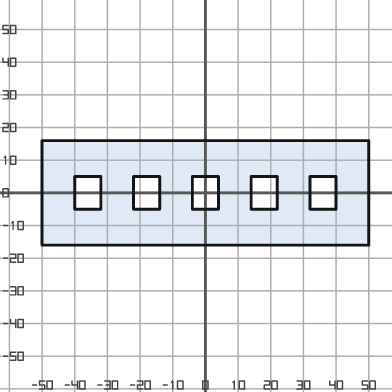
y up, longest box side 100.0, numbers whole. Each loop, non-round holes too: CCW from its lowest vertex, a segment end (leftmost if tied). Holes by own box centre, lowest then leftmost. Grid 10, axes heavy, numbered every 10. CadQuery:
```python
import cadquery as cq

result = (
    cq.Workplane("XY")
    .moveTo(-50.0, -16.0)
    .lineTo(50.0, -16.0)
    .lineTo(50.0, 16.0)
    .lineTo(-50.0, 16.0)
    .close()
    .moveTo(-40.0, -5.0)
    .lineTo(-32.0, -5.0)
    .lineTo(-32.0, 5.0)
    .lineTo(-40.0, 5.0)
    .close()
    .moveTo(-22.0, -5.0)
    .lineTo(-14.0, -5.0)
    .lineTo(-14.0, 5.0)
    .lineTo(-22.0, 5.0)
    .close()
    .moveTo(-4.0, -5.0)
    .lineTo(4.0, -5.0)
    .lineTo(4.0, 5.0)
    .lineTo(-4.0, 5.0)
    .close()
    .moveTo(14.0, -5.0)
    .lineTo(22.0, -5.0)
    .lineTo(22.0, 5.0)
    .lineTo(14.0, 5.0)
    .close()
    .moveTo(32.0, -5.0)
    .lineTo(40.0, -5.0)
    .lineTo(40.0, 5.0)
    .lineTo(32.0, 5.0)
    .close()
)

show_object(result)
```